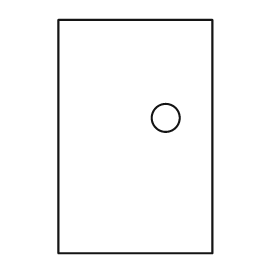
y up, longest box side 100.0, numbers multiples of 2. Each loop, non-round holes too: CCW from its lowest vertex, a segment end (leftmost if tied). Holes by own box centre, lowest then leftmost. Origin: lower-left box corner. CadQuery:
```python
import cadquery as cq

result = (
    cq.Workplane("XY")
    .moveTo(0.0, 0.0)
    .lineTo(66.0, 0.0)
    .lineTo(66.0, 100.0)
    .lineTo(0.0, 100.0)
    .close()
    .moveTo(46.0, 58.0)
    .circle(6.0)
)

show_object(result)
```